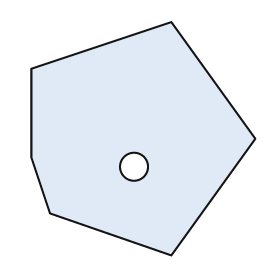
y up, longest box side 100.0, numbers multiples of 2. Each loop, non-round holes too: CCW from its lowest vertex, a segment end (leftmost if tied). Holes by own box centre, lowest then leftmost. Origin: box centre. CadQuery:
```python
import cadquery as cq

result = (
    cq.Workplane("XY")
    .moveTo(12.0, -50.0)
    .lineTo(48.0, 0.0)
    .lineTo(12.0, 50.0)
    .lineTo(-48.0, 30.0)
    .lineTo(-48.0, -8.0)
    .lineTo(-40.0, -32.0)
    .close()
    .moveTo(-4.0, -12.0)
    .circle(6.0)
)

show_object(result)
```